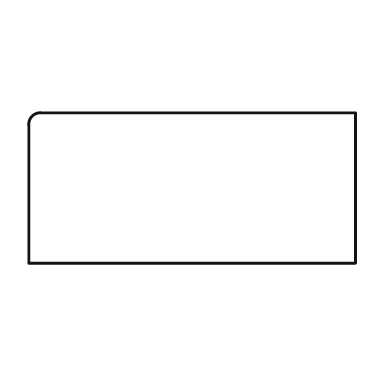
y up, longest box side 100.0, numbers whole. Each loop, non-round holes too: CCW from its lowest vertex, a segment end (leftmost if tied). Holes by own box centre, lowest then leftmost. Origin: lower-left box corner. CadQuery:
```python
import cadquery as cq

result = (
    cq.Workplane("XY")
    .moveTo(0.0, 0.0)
    .lineTo(100.0, 0.0)
    .lineTo(100.0, 46.0)
    .lineTo(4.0, 46.0)
    .threePointArc((1.0, 45.0), (0.0, 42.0))
    .close()
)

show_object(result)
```